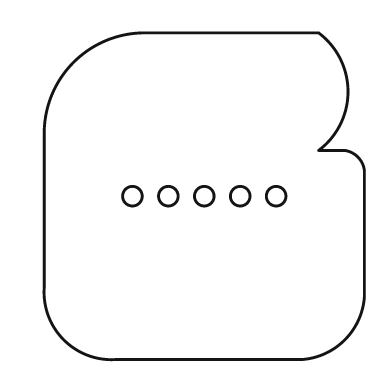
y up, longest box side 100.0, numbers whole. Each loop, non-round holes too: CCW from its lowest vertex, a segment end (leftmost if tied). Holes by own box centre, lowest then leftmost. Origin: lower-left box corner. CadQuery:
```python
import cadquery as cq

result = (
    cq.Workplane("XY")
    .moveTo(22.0, 0.0)
    .lineTo(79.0, 0.0)
    .threePointArc((92.0, 6.0), (98.0, 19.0))
    .lineTo(98.0, 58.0)
    .threePointArc((96.0, 62.0), (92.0, 64.0))
    .lineTo(84.0, 64.0)
    .threePointArc((93.0, 82.0), (84.0, 100.0))
    .lineTo(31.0, 100.0)
    .threePointArc((9.0, 91.0), (0.0, 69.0))
    .lineTo(0.0, 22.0)
    .threePointArc((6.0, 6.0), (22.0, 0.0))
    .close()
    .moveTo(27.0, 50.0)
    .circle(3.0)
    .moveTo(38.0, 50.0)
    .circle(3.0)
    .moveTo(49.0, 50.0)
    .circle(3.0)
    .moveTo(60.0, 50.0)
    .circle(3.0)
    .moveTo(71.0, 50.0)
    .circle(3.0)
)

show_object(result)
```